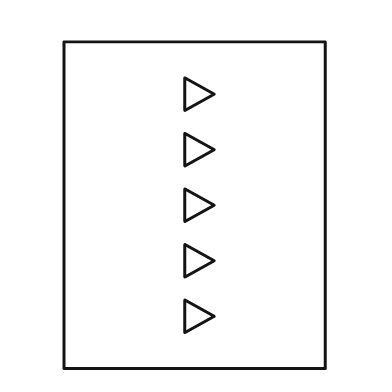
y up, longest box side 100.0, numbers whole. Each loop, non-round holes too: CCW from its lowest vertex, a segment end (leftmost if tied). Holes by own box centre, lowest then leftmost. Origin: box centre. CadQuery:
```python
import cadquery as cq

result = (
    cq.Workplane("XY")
    .moveTo(-40.0, -50.0)
    .lineTo(40.0, -50.0)
    .lineTo(40.0, 50.0)
    .lineTo(-40.0, 50.0)
    .close()
    .moveTo(-3.0, -39.0)
    .lineTo(6.0, -34.0)
    .lineTo(-3.0, -29.0)
    .close()
    .moveTo(-3.0, -22.0)
    .lineTo(6.0, -17.0)
    .lineTo(-3.0, -12.0)
    .close()
    .moveTo(-3.0, -5.0)
    .lineTo(6.0, 0.0)
    .lineTo(-3.0, 5.0)
    .close()
    .moveTo(-3.0, 12.0)
    .lineTo(6.0, 17.0)
    .lineTo(-3.0, 22.0)
    .close()
    .moveTo(-3.0, 29.0)
    .lineTo(6.0, 34.0)
    .lineTo(-3.0, 39.0)
    .close()
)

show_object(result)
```